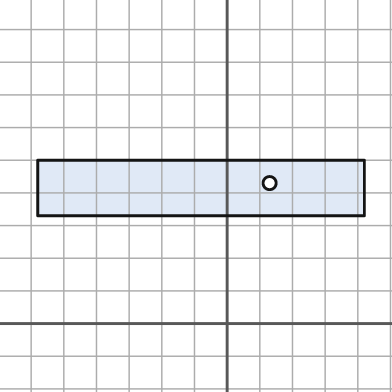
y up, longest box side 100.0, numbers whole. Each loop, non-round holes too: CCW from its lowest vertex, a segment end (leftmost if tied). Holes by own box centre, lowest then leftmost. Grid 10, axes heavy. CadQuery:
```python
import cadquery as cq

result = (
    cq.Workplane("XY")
    .moveTo(-58.0, 33.0)
    .lineTo(42.0, 33.0)
    .lineTo(42.0, 50.0)
    .lineTo(-58.0, 50.0)
    .close()
    .moveTo(13.0, 43.0)
    .circle(2.0)
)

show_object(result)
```